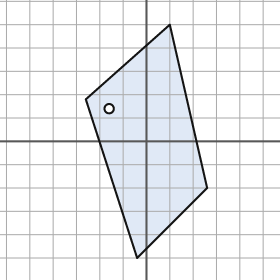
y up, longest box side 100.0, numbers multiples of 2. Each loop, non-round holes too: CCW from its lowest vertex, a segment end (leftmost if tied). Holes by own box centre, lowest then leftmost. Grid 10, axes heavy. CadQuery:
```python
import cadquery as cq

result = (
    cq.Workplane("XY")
    .moveTo(-4.0, -50.0)
    .lineTo(26.0, -20.0)
    .lineTo(10.0, 50.0)
    .lineTo(-26.0, 18.0)
    .close()
    .moveTo(-16.0, 14.0)
    .circle(2.0)
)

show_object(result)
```